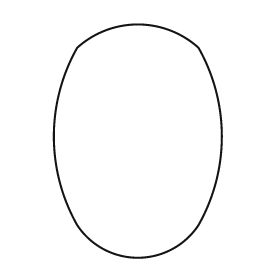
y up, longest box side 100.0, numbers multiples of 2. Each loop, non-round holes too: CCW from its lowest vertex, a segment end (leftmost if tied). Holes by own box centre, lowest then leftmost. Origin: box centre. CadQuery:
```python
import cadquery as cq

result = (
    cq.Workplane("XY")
    .moveTo(-26.0, -36.0)
    .threePointArc((0.0, -50.0), (26.0, -36.0))
    .threePointArc((36.0, 2.0), (26.0, 40.0))
    .threePointArc((0.0, 50.0), (-26.0, 40.0))
    .threePointArc((-36.0, 2.0), (-26.0, -36.0))
    .close()
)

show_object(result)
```